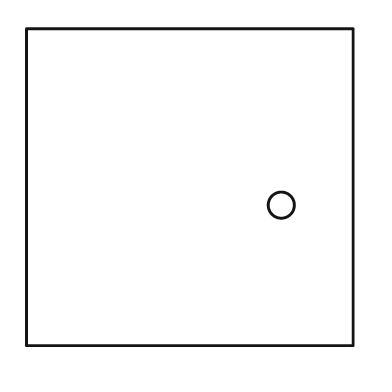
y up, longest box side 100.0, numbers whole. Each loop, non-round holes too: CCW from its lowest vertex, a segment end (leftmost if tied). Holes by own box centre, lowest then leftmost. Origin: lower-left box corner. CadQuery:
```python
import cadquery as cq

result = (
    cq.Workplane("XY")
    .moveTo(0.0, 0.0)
    .lineTo(100.0, 0.0)
    .lineTo(100.0, 97.0)
    .lineTo(0.0, 97.0)
    .close()
    .moveTo(78.0, 43.0)
    .circle(4.0)
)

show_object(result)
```